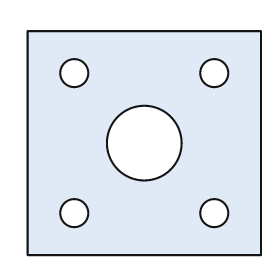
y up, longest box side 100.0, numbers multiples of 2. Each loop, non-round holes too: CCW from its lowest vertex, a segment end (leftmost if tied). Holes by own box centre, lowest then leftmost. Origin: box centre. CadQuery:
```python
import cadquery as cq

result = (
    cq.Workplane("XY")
    .moveTo(-50.0, -48.0)
    .lineTo(50.0, -48.0)
    .lineTo(50.0, 48.0)
    .lineTo(-50.0, 48.0)
    .close()
    .moveTo(-30.0, -30.0)
    .circle(6.0)
    .moveTo(30.0, -30.0)
    .circle(6.0)
    .moveTo(0.0, 0.0)
    .circle(16.0)
    .moveTo(-30.0, 30.0)
    .circle(6.0)
    .moveTo(30.0, 30.0)
    .circle(6.0)
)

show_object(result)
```